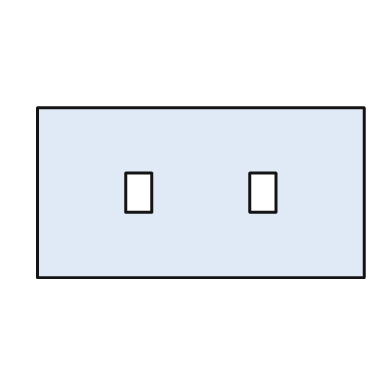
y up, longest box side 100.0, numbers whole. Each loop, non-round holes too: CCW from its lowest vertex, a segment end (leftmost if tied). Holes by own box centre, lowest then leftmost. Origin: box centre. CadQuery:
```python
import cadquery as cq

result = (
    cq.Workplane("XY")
    .moveTo(-50.0, -26.0)
    .lineTo(50.0, -26.0)
    .lineTo(50.0, 26.0)
    .lineTo(-50.0, 26.0)
    .close()
    .moveTo(-23.0, -6.0)
    .lineTo(-15.0, -6.0)
    .lineTo(-15.0, 6.0)
    .lineTo(-23.0, 6.0)
    .close()
    .moveTo(15.0, -6.0)
    .lineTo(23.0, -6.0)
    .lineTo(23.0, 6.0)
    .lineTo(15.0, 6.0)
    .close()
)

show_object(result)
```